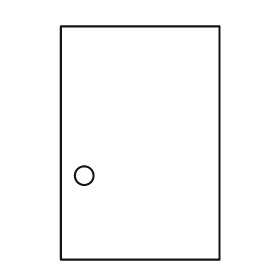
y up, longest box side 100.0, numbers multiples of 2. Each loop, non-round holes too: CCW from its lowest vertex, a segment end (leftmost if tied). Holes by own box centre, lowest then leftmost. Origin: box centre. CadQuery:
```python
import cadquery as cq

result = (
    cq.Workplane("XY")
    .moveTo(-34.0, -50.0)
    .lineTo(34.0, -50.0)
    .lineTo(34.0, 50.0)
    .lineTo(-34.0, 50.0)
    .close()
    .moveTo(-24.0, -14.0)
    .circle(4.0)
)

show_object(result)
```